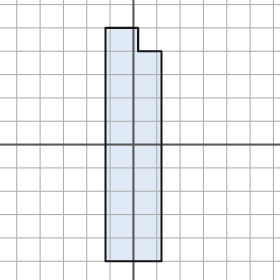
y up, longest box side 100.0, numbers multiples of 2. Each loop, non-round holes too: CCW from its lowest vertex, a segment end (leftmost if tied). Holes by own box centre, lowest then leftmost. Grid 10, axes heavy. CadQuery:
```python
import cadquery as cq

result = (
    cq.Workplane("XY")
    .moveTo(-12.0, -50.0)
    .lineTo(12.0, -50.0)
    .lineTo(12.0, 40.0)
    .lineTo(2.0, 40.0)
    .lineTo(2.0, 50.0)
    .lineTo(-12.0, 50.0)
    .close()
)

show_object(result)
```